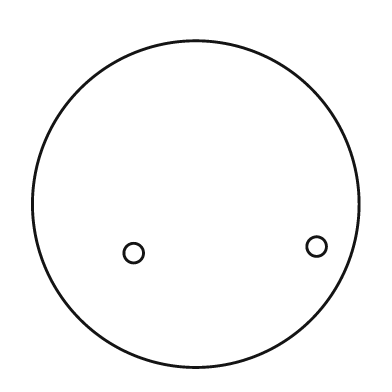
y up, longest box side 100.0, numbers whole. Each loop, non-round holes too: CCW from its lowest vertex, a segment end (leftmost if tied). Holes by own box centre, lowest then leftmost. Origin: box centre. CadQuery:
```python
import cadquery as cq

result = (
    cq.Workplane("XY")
    .moveTo(0.0, 0.0)
    .circle(50.0)
    .moveTo(-19.0, -15.0)
    .circle(3.0)
    .moveTo(37.0, -13.0)
    .circle(3.0)
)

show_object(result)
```